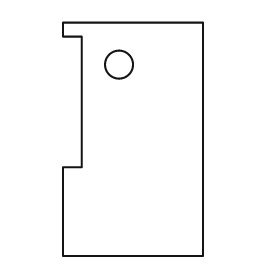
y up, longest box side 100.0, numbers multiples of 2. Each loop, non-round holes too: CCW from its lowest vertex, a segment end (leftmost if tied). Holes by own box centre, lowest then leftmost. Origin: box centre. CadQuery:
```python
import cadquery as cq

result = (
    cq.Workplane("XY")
    .moveTo(-30.0, -50.0)
    .lineTo(30.0, -50.0)
    .lineTo(30.0, 50.0)
    .lineTo(-30.0, 50.0)
    .lineTo(-30.0, 44.0)
    .lineTo(-22.0, 44.0)
    .lineTo(-22.0, -12.0)
    .lineTo(-30.0, -12.0)
    .close()
    .moveTo(-6.0, 32.0)
    .circle(6.0)
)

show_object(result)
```